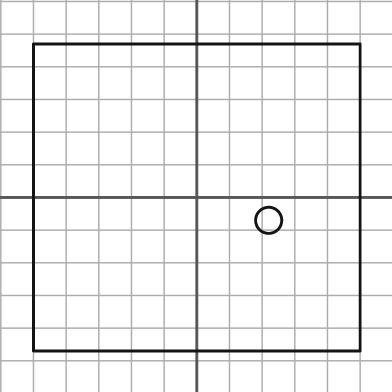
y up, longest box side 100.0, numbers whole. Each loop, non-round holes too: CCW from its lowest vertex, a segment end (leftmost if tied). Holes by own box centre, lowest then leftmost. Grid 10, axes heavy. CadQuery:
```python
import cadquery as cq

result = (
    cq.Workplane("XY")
    .moveTo(-50.0, -47.0)
    .lineTo(50.0, -47.0)
    .lineTo(50.0, 47.0)
    .lineTo(-50.0, 47.0)
    .close()
    .moveTo(22.0, -7.0)
    .circle(4.0)
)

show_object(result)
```